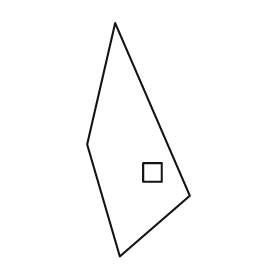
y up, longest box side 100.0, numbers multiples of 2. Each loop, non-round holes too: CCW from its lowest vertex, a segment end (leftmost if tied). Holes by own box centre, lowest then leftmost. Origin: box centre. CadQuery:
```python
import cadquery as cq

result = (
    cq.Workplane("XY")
    .moveTo(-8.0, -50.0)
    .lineTo(22.0, -24.0)
    .lineTo(-10.0, 50.0)
    .lineTo(-22.0, -2.0)
    .close()
    .moveTo(2.0, -18.0)
    .lineTo(10.0, -18.0)
    .lineTo(10.0, -10.0)
    .lineTo(2.0, -10.0)
    .close()
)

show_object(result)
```